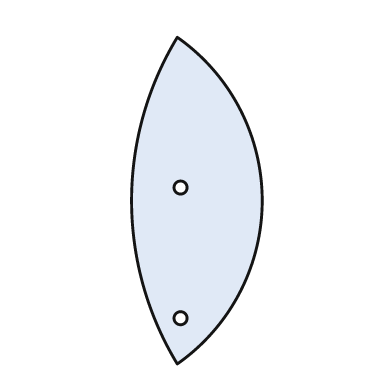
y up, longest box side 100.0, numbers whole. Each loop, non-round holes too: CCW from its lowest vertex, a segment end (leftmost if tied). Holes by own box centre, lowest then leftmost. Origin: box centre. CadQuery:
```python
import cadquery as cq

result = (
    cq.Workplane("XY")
    .moveTo(-6.0, -50.0)
    .threePointArc((20.0, 0.0), (-6.0, 50.0))
    .threePointArc((-20.0, 0.0), (-6.0, -50.0))
    .close()
    .moveTo(-5.0, -36.0)
    .circle(2.0)
    .moveTo(-5.0, 4.0)
    .circle(2.0)
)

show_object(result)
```